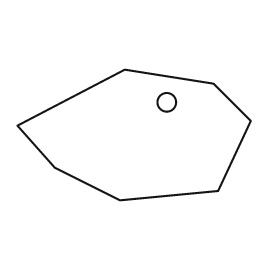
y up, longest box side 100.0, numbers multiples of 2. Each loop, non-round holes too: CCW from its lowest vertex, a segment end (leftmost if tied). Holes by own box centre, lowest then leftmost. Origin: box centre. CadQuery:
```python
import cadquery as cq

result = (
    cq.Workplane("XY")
    .moveTo(-6.0, -28.0)
    .lineTo(36.0, -24.0)
    .lineTo(50.0, 6.0)
    .lineTo(34.0, 22.0)
    .lineTo(-4.0, 28.0)
    .lineTo(-50.0, 4.0)
    .lineTo(-34.0, -14.0)
    .close()
    .moveTo(14.0, 14.0)
    .circle(4.0)
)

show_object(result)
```